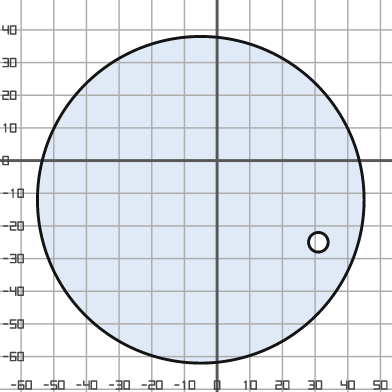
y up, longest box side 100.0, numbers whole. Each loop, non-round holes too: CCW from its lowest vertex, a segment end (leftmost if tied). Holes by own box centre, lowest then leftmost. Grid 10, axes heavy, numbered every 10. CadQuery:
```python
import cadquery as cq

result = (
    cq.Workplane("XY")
    .moveTo(-5.0, -12.0)
    .circle(50.0)
    .moveTo(31.0, -25.0)
    .circle(3.0)
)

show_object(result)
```